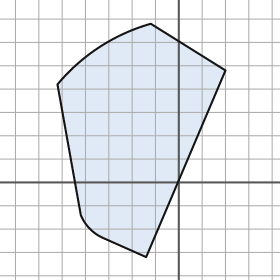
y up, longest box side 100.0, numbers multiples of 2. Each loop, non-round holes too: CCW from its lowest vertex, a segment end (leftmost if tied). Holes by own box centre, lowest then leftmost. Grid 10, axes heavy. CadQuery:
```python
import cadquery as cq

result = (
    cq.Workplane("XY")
    .moveTo(-14.0, -32.0)
    .lineTo(20.0, 48.0)
    .lineTo(-12.0, 68.0)
    .threePointArc((-34.0, 58.0), (-52.0, 42.0))
    .lineTo(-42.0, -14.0)
    .threePointArc((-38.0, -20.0), (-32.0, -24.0))
    .close()
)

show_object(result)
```